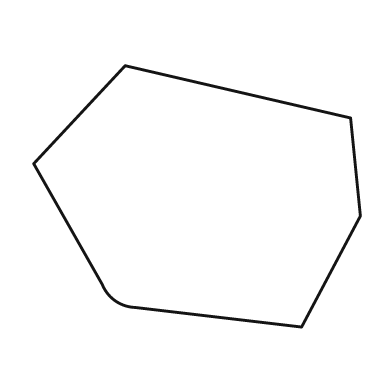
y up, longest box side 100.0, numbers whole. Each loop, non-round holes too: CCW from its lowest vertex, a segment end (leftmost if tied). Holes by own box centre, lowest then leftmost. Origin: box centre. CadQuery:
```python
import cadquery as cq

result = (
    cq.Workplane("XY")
    .moveTo(32.0, -40.0)
    .lineTo(50.0, -6.0)
    .lineTo(47.0, 24.0)
    .lineTo(-22.0, 40.0)
    .lineTo(-50.0, 10.0)
    .lineTo(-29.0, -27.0)
    .threePointArc((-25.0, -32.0), (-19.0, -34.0))
    .close()
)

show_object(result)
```